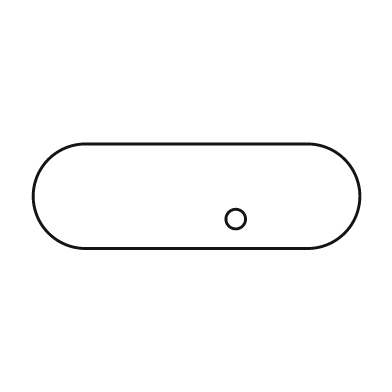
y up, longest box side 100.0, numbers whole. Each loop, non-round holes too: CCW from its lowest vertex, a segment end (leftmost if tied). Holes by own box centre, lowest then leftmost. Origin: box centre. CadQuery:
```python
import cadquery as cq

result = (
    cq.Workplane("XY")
    .moveTo(-34.0, -16.0)
    .lineTo(34.0, -16.0)
    .threePointArc((50.0, 0.0), (34.0, 16.0))
    .lineTo(-34.0, 16.0)
    .threePointArc((-50.0, 0.0), (-34.0, -16.0))
    .close()
    .moveTo(12.0, -7.0)
    .circle(3.0)
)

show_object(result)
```